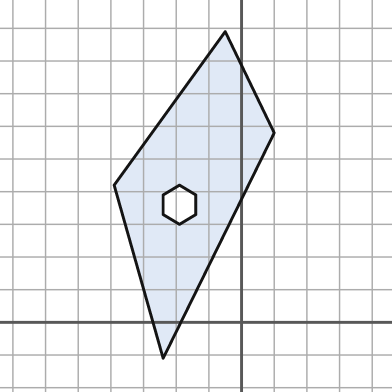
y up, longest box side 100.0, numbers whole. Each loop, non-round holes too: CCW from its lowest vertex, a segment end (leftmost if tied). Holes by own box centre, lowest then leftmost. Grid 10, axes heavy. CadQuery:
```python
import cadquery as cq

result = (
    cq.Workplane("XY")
    .moveTo(-24.0, -11.0)
    .lineTo(10.0, 58.0)
    .lineTo(-5.0, 89.0)
    .lineTo(-39.0, 42.0)
    .close()
    .moveTo(-19.0, 30.0)
    .lineTo(-14.0, 33.0)
    .lineTo(-14.0, 39.0)
    .lineTo(-19.0, 42.0)
    .lineTo(-24.0, 39.0)
    .lineTo(-24.0, 33.0)
    .close()
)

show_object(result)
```